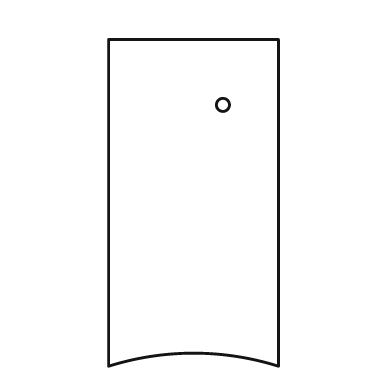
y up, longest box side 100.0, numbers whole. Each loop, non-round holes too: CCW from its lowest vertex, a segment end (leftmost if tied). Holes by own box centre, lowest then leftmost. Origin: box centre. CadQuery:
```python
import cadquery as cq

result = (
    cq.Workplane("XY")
    .moveTo(-26.0, -50.0)
    .threePointArc((0.0, -46.0), (26.0, -50.0))
    .lineTo(26.0, 50.0)
    .lineTo(-26.0, 50.0)
    .close()
    .moveTo(9.0, 30.0)
    .circle(2.0)
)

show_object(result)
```